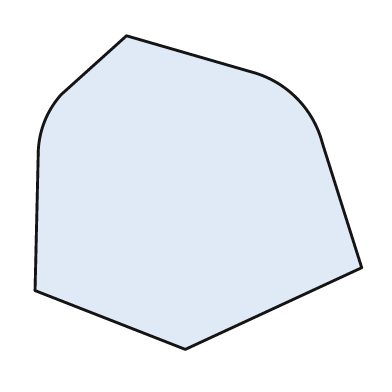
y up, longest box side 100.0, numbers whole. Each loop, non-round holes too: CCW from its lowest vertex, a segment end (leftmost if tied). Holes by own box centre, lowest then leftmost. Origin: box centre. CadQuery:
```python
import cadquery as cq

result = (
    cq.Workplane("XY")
    .moveTo(-4.0, -48.0)
    .lineTo(50.0, -23.0)
    .lineTo(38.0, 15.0)
    .threePointArc((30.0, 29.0), (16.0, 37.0))
    .lineTo(-22.0, 48.0)
    .lineTo(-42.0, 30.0)
    .threePointArc((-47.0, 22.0), (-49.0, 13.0))
    .lineTo(-50.0, -30.0)
    .close()
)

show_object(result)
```